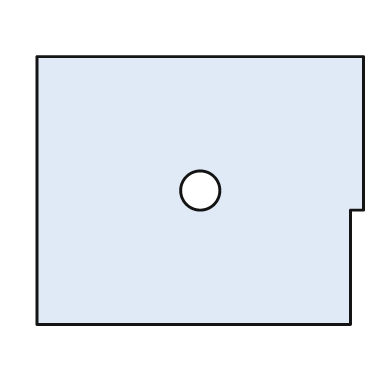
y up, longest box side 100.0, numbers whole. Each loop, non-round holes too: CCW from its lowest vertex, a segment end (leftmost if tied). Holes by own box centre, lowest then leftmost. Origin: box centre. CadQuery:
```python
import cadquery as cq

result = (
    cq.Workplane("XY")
    .moveTo(-50.0, -41.0)
    .lineTo(46.0, -41.0)
    .lineTo(46.0, -6.0)
    .lineTo(50.0, -6.0)
    .lineTo(50.0, 41.0)
    .lineTo(-50.0, 41.0)
    .close()
    .moveTo(0.0, 0.0)
    .circle(6.0)
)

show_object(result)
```